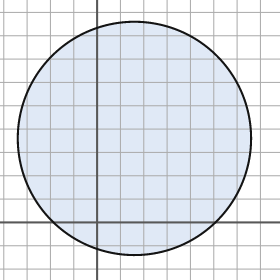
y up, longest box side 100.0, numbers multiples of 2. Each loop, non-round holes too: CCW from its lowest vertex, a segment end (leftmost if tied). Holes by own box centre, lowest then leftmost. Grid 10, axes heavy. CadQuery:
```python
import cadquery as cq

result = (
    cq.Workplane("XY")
    .moveTo(16.0, 36.0)
    .circle(50.0)
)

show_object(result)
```